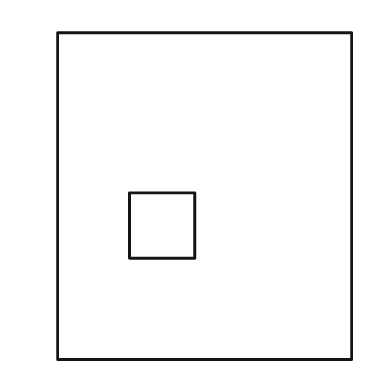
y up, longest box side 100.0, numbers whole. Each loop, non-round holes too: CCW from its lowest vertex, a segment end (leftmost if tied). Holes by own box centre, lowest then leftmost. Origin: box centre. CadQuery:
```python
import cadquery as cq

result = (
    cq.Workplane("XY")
    .moveTo(-45.0, -50.0)
    .lineTo(45.0, -50.0)
    .lineTo(45.0, 50.0)
    .lineTo(-45.0, 50.0)
    .close()
    .moveTo(-23.0, -19.0)
    .lineTo(-3.0, -19.0)
    .lineTo(-3.0, 1.0)
    .lineTo(-23.0, 1.0)
    .close()
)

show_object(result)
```